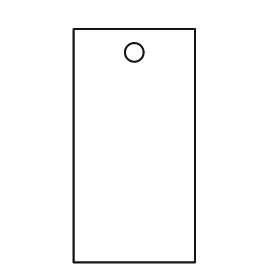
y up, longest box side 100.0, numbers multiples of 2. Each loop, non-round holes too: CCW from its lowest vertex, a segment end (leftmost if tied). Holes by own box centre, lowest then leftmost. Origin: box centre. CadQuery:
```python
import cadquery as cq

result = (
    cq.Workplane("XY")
    .moveTo(-26.0, -50.0)
    .lineTo(26.0, -50.0)
    .lineTo(26.0, 50.0)
    .lineTo(-26.0, 50.0)
    .close()
    .moveTo(0.0, 40.0)
    .circle(4.0)
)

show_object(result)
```